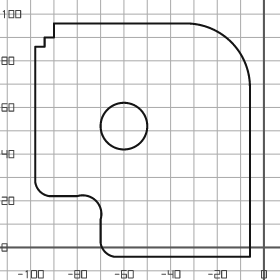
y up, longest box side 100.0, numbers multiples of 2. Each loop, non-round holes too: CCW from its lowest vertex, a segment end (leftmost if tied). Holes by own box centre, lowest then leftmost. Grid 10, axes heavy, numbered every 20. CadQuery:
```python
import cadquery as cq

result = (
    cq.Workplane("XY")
    .moveTo(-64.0, -4.0)
    .lineTo(-6.0, -4.0)
    .lineTo(-6.0, 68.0)
    .threePointArc((-14.0, 88.0), (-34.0, 96.0))
    .lineTo(-90.0, 96.0)
    .lineTo(-90.0, 90.0)
    .lineTo(-94.0, 90.0)
    .lineTo(-94.0, 86.0)
    .lineTo(-98.0, 86.0)
    .lineTo(-98.0, 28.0)
    .threePointArc((-96.0, 24.0), (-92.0, 22.0))
    .lineTo(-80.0, 22.0)
    .threePointArc((-72.0, 20.0), (-70.0, 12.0))
    .lineTo(-70.0, 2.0)
    .threePointArc((-68.0, -2.0), (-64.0, -4.0))
    .close()
    .moveTo(-60.0, 52.0)
    .circle(10.0)
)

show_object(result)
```